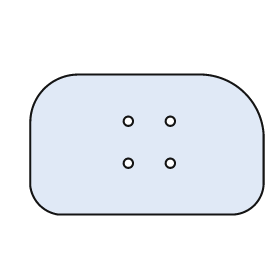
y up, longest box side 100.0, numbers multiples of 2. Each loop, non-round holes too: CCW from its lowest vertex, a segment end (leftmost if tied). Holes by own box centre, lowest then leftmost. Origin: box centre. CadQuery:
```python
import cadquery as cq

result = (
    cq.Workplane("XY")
    .moveTo(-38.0, -30.0)
    .lineTo(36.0, -30.0)
    .threePointArc((46.0, -26.0), (50.0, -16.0))
    .lineTo(50.0, 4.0)
    .threePointArc((42.0, 22.0), (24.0, 30.0))
    .lineTo(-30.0, 30.0)
    .threePointArc((-44.0, 24.0), (-50.0, 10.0))
    .lineTo(-50.0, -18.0)
    .threePointArc((-46.0, -26.0), (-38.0, -30.0))
    .close()
    .moveTo(-8.0, -8.0)
    .circle(2.0)
    .moveTo(10.0, -8.0)
    .circle(2.0)
    .moveTo(-8.0, 10.0)
    .circle(2.0)
    .moveTo(10.0, 10.0)
    .circle(2.0)
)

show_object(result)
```